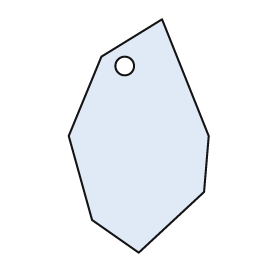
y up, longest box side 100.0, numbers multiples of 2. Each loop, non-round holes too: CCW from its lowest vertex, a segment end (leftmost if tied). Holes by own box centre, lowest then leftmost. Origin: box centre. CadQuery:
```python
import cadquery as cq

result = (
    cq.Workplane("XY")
    .moveTo(0.0, -50.0)
    .lineTo(28.0, -24.0)
    .lineTo(30.0, 0.0)
    .lineTo(10.0, 50.0)
    .lineTo(-16.0, 34.0)
    .lineTo(-30.0, 0.0)
    .lineTo(-20.0, -36.0)
    .close()
    .moveTo(-6.0, 30.0)
    .circle(4.0)
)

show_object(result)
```